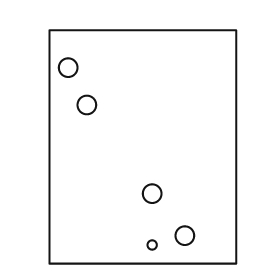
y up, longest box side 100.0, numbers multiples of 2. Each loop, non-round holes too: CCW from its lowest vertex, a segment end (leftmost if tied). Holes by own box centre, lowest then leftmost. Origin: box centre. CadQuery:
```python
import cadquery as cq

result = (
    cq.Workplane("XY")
    .moveTo(-40.0, -50.0)
    .lineTo(40.0, -50.0)
    .lineTo(40.0, 50.0)
    .lineTo(-40.0, 50.0)
    .close()
    .moveTo(4.0, -42.0)
    .circle(2.0)
    .moveTo(18.0, -38.0)
    .circle(4.0)
    .moveTo(4.0, -20.0)
    .circle(4.0)
    .moveTo(-24.0, 18.0)
    .circle(4.0)
    .moveTo(-32.0, 34.0)
    .circle(4.0)
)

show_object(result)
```